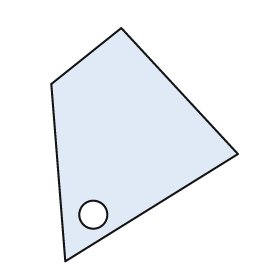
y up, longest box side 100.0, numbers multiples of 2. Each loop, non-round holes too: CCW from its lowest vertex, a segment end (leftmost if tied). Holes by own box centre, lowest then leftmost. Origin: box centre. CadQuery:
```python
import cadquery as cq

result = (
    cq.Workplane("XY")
    .moveTo(-34.0, -50.0)
    .lineTo(40.0, -4.0)
    .lineTo(-10.0, 50.0)
    .lineTo(-40.0, 26.0)
    .close()
    .moveTo(-22.0, -30.0)
    .circle(6.0)
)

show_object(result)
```